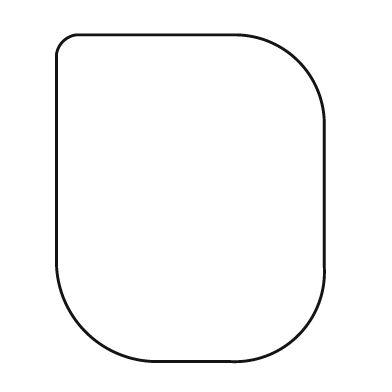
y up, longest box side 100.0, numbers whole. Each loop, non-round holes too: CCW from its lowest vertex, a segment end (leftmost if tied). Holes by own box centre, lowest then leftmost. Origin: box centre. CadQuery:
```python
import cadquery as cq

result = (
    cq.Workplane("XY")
    .moveTo(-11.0, -50.0)
    .lineTo(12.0, -50.0)
    .threePointArc((33.0, -42.0), (41.0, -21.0))
    .lineTo(41.0, 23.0)
    .threePointArc((33.0, 42.0), (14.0, 50.0))
    .lineTo(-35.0, 50.0)
    .threePointArc((-39.0, 48.0), (-41.0, 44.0))
    .lineTo(-41.0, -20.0)
    .threePointArc((-32.0, -41.0), (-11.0, -50.0))
    .close()
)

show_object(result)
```